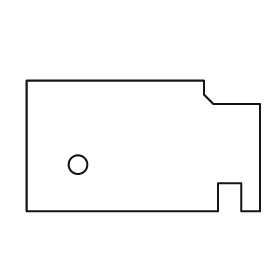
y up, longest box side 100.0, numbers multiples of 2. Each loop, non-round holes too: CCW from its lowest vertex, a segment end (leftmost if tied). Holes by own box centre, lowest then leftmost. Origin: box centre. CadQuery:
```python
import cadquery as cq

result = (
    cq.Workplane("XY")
    .moveTo(-50.0, -28.0)
    .lineTo(32.0, -28.0)
    .lineTo(32.0, -16.0)
    .lineTo(42.0, -16.0)
    .lineTo(42.0, -28.0)
    .lineTo(50.0, -28.0)
    .lineTo(50.0, 18.0)
    .lineTo(30.0, 18.0)
    .lineTo(26.0, 22.0)
    .lineTo(26.0, 28.0)
    .lineTo(-50.0, 28.0)
    .close()
    .moveTo(-28.0, -8.0)
    .circle(4.0)
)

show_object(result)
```